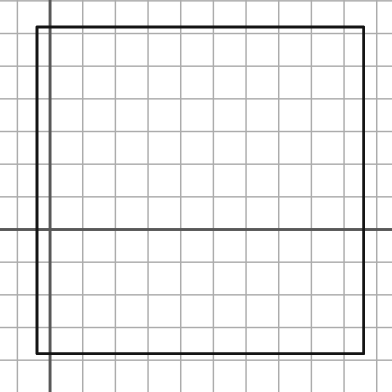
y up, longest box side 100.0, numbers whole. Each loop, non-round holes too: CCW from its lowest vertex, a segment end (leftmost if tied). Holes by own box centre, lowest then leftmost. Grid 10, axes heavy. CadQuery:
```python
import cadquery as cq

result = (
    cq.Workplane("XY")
    .moveTo(-4.0, -38.0)
    .lineTo(96.0, -38.0)
    .lineTo(96.0, 62.0)
    .lineTo(-4.0, 62.0)
    .close()
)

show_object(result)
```